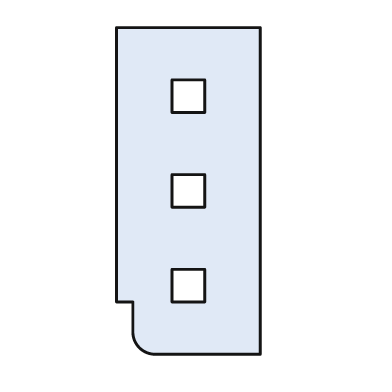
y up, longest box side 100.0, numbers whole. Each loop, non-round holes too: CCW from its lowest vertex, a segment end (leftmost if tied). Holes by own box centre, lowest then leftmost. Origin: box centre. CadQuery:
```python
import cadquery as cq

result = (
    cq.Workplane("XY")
    .moveTo(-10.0, -50.0)
    .lineTo(22.0, -50.0)
    .lineTo(22.0, 50.0)
    .lineTo(-22.0, 50.0)
    .lineTo(-22.0, -34.0)
    .lineTo(-17.0, -34.0)
    .lineTo(-17.0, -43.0)
    .threePointArc((-15.0, -48.0), (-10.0, -50.0))
    .close()
    .moveTo(-5.0, -34.0)
    .lineTo(5.0, -34.0)
    .lineTo(5.0, -24.0)
    .lineTo(-5.0, -24.0)
    .close()
    .moveTo(-5.0, -5.0)
    .lineTo(5.0, -5.0)
    .lineTo(5.0, 5.0)
    .lineTo(-5.0, 5.0)
    .close()
    .moveTo(-5.0, 24.0)
    .lineTo(5.0, 24.0)
    .lineTo(5.0, 34.0)
    .lineTo(-5.0, 34.0)
    .close()
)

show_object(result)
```